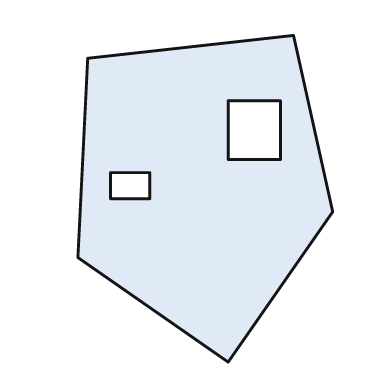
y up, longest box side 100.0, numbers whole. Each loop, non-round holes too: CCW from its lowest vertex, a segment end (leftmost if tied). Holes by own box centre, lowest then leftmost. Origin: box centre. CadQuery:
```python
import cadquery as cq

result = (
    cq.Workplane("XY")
    .moveTo(7.0, -50.0)
    .lineTo(39.0, -4.0)
    .lineTo(27.0, 50.0)
    .lineTo(-36.0, 43.0)
    .lineTo(-39.0, -18.0)
    .close()
    .moveTo(-29.0, 0.0)
    .lineTo(-17.0, 0.0)
    .lineTo(-17.0, 8.0)
    .lineTo(-29.0, 8.0)
    .close()
    .moveTo(7.0, 12.0)
    .lineTo(23.0, 12.0)
    .lineTo(23.0, 30.0)
    .lineTo(7.0, 30.0)
    .close()
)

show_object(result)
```